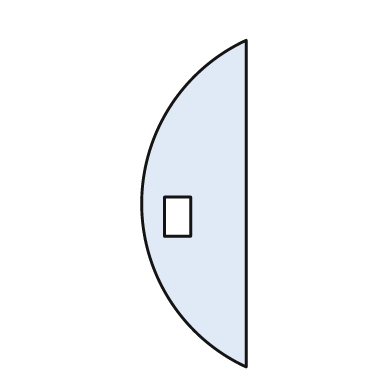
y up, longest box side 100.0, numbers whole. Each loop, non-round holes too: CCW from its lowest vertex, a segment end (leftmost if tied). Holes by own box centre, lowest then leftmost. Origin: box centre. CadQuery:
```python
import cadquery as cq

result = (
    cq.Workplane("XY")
    .moveTo(16.0, -50.0)
    .lineTo(16.0, 50.0)
    .threePointArc((-16.0, 0.0), (16.0, -50.0))
    .close()
    .moveTo(-9.0, -10.0)
    .lineTo(-1.0, -10.0)
    .lineTo(-1.0, 2.0)
    .lineTo(-9.0, 2.0)
    .close()
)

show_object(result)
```